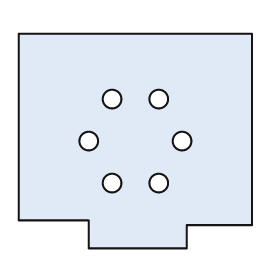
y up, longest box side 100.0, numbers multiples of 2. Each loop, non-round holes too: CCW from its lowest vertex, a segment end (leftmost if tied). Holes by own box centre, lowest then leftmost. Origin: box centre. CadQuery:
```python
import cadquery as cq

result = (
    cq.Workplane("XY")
    .moveTo(-20.0, -46.0)
    .lineTo(22.0, -46.0)
    .lineTo(22.0, -36.0)
    .lineTo(50.0, -36.0)
    .lineTo(50.0, 46.0)
    .lineTo(-50.0, 46.0)
    .lineTo(-50.0, -34.0)
    .lineTo(-20.0, -34.0)
    .close()
    .moveTo(-10.0, -18.0)
    .circle(4.0)
    .moveTo(10.0, -18.0)
    .circle(4.0)
    .moveTo(-20.0, 0.0)
    .circle(4.0)
    .moveTo(20.0, 0.0)
    .circle(4.0)
    .moveTo(-10.0, 18.0)
    .circle(4.0)
    .moveTo(10.0, 18.0)
    .circle(4.0)
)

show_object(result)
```